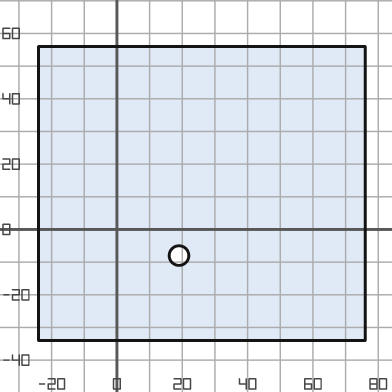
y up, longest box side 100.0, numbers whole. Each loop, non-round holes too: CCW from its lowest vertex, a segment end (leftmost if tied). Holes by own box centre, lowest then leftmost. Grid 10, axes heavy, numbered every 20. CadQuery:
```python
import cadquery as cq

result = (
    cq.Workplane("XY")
    .moveTo(-24.0, -34.0)
    .lineTo(76.0, -34.0)
    .lineTo(76.0, 56.0)
    .lineTo(-24.0, 56.0)
    .close()
    .moveTo(19.0, -8.0)
    .circle(3.0)
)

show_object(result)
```